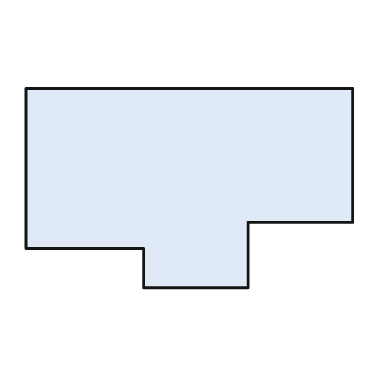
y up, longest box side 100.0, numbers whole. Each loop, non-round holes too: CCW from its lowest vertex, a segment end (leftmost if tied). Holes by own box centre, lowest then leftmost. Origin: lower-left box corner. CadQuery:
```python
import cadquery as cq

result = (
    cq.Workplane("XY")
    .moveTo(36.0, 0.0)
    .lineTo(68.0, 0.0)
    .lineTo(68.0, 20.0)
    .lineTo(100.0, 20.0)
    .lineTo(100.0, 61.0)
    .lineTo(0.0, 61.0)
    .lineTo(0.0, 12.0)
    .lineTo(36.0, 12.0)
    .close()
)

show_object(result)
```